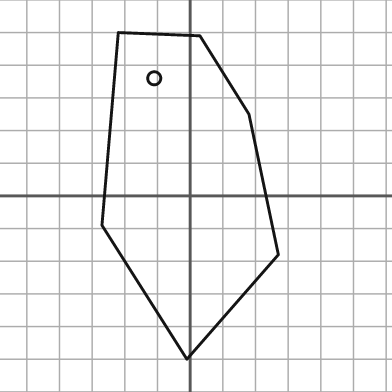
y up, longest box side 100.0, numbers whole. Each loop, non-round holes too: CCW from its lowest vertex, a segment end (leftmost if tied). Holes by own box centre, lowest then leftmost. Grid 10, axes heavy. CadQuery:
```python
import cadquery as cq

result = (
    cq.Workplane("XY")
    .moveTo(-1.0, -50.0)
    .lineTo(27.0, -18.0)
    .lineTo(18.0, 25.0)
    .lineTo(3.0, 49.0)
    .lineTo(-22.0, 50.0)
    .lineTo(-27.0, -9.0)
    .close()
    .moveTo(-11.0, 36.0)
    .circle(2.0)
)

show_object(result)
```